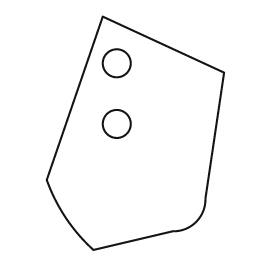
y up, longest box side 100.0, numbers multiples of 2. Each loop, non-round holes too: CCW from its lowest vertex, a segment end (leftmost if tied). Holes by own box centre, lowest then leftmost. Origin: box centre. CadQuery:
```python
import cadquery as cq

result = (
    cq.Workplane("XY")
    .moveTo(-18.0, -50.0)
    .lineTo(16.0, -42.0)
    .threePointArc((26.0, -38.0), (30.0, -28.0))
    .lineTo(38.0, 26.0)
    .lineTo(-14.0, 50.0)
    .lineTo(-38.0, -20.0)
    .threePointArc((-30.0, -36.0), (-18.0, -50.0))
    .close()
    .moveTo(-8.0, 4.0)
    .circle(6.0)
    .moveTo(-8.0, 30.0)
    .circle(6.0)
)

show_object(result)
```